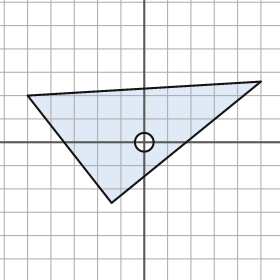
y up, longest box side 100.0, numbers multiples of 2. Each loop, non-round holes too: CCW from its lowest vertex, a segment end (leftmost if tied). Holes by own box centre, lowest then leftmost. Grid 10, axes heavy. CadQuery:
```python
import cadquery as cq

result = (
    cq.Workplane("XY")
    .moveTo(-14.0, -26.0)
    .lineTo(50.0, 26.0)
    .lineTo(-50.0, 20.0)
    .close()
    .moveTo(0.0, 0.0)
    .circle(4.0)
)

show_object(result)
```